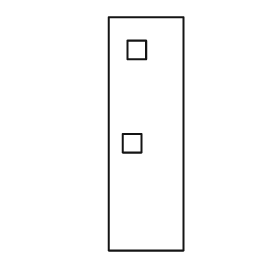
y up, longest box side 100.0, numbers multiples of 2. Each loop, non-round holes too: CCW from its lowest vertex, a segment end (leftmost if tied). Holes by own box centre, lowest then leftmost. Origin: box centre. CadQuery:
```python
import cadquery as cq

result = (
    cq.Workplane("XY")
    .moveTo(-16.0, -50.0)
    .lineTo(16.0, -50.0)
    .lineTo(16.0, 50.0)
    .lineTo(-16.0, 50.0)
    .close()
    .moveTo(-10.0, -8.0)
    .lineTo(-2.0, -8.0)
    .lineTo(-2.0, 0.0)
    .lineTo(-10.0, 0.0)
    .close()
    .moveTo(-8.0, 32.0)
    .lineTo(0.0, 32.0)
    .lineTo(0.0, 40.0)
    .lineTo(-8.0, 40.0)
    .close()
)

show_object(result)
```